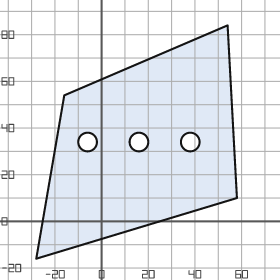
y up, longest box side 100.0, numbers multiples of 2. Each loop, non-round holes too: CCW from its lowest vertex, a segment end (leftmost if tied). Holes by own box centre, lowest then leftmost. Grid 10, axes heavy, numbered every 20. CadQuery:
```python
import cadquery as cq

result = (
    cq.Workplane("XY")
    .moveTo(-28.0, -16.0)
    .lineTo(58.0, 10.0)
    .lineTo(54.0, 84.0)
    .lineTo(-16.0, 54.0)
    .close()
    .moveTo(-6.0, 34.0)
    .circle(4.0)
    .moveTo(16.0, 34.0)
    .circle(4.0)
    .moveTo(38.0, 34.0)
    .circle(4.0)
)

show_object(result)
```